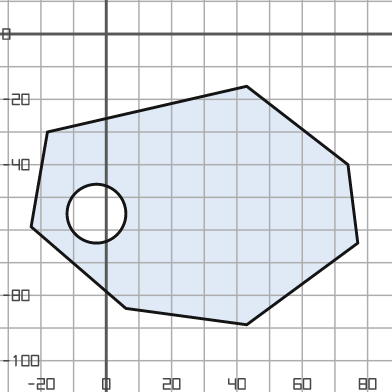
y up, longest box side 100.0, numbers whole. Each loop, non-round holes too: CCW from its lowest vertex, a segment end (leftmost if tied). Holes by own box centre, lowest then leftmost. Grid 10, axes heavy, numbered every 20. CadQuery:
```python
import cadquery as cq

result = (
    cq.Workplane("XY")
    .moveTo(43.0, -89.0)
    .lineTo(77.0, -64.0)
    .lineTo(74.0, -40.0)
    .lineTo(43.0, -16.0)
    .lineTo(-18.0, -30.0)
    .lineTo(-23.0, -59.0)
    .lineTo(6.0, -84.0)
    .close()
    .moveTo(-3.0, -55.0)
    .circle(9.0)
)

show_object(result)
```